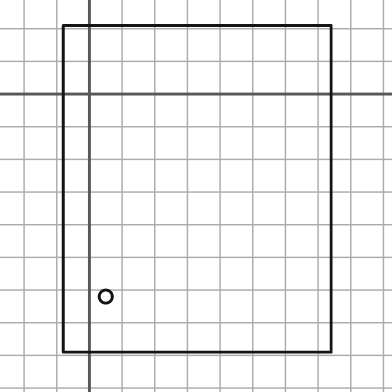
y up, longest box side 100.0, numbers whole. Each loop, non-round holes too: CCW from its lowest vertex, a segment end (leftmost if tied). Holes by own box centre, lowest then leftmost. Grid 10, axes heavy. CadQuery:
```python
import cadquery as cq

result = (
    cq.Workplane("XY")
    .moveTo(-8.0, -79.0)
    .lineTo(74.0, -79.0)
    .lineTo(74.0, 21.0)
    .lineTo(-8.0, 21.0)
    .close()
    .moveTo(5.0, -62.0)
    .circle(2.0)
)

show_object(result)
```